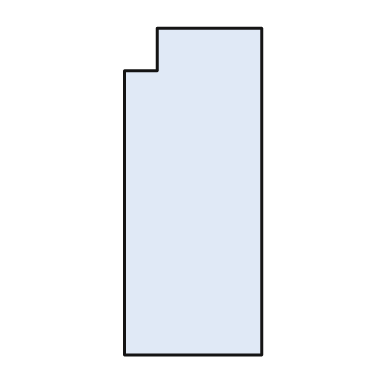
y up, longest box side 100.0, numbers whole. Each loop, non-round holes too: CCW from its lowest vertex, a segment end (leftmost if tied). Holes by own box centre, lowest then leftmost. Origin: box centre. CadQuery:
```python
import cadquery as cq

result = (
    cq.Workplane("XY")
    .moveTo(-21.0, -50.0)
    .lineTo(21.0, -50.0)
    .lineTo(21.0, 50.0)
    .lineTo(-11.0, 50.0)
    .lineTo(-11.0, 37.0)
    .lineTo(-21.0, 37.0)
    .close()
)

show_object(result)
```